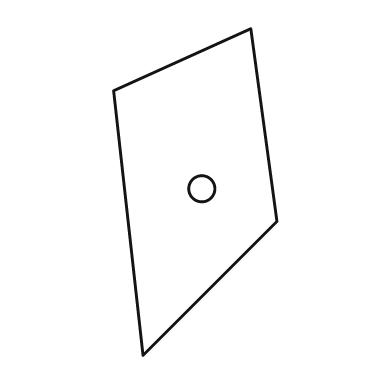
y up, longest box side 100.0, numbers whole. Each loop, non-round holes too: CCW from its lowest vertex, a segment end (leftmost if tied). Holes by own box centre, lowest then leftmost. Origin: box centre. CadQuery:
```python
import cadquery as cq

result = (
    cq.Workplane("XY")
    .moveTo(-16.0, -50.0)
    .lineTo(25.0, -9.0)
    .lineTo(17.0, 50.0)
    .lineTo(-25.0, 31.0)
    .close()
    .moveTo(2.0, 1.0)
    .circle(4.0)
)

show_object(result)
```